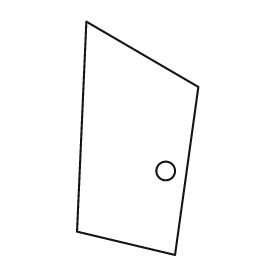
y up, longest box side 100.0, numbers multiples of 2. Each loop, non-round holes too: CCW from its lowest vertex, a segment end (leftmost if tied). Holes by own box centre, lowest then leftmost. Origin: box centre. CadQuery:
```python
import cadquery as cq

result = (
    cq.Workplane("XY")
    .moveTo(16.0, -50.0)
    .lineTo(26.0, 22.0)
    .lineTo(-22.0, 50.0)
    .lineTo(-26.0, -40.0)
    .close()
    .moveTo(12.0, -14.0)
    .circle(4.0)
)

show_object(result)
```